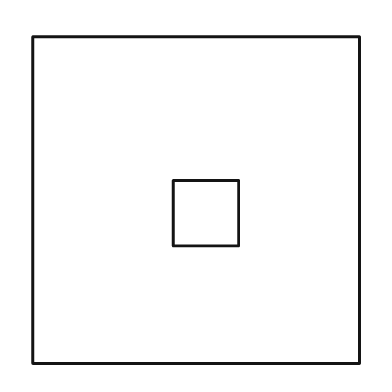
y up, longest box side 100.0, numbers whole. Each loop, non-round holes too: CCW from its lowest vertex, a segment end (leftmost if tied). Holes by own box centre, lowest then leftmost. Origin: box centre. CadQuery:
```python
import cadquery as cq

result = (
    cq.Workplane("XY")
    .moveTo(-50.0, -50.0)
    .lineTo(50.0, -50.0)
    .lineTo(50.0, 50.0)
    .lineTo(-50.0, 50.0)
    .close()
    .moveTo(-7.0, -14.0)
    .lineTo(13.0, -14.0)
    .lineTo(13.0, 6.0)
    .lineTo(-7.0, 6.0)
    .close()
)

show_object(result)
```